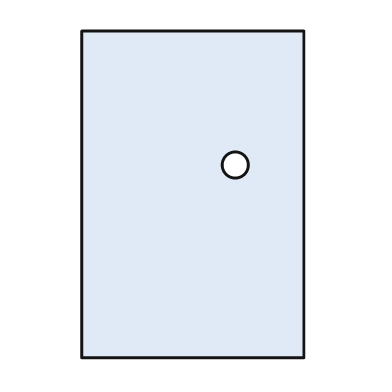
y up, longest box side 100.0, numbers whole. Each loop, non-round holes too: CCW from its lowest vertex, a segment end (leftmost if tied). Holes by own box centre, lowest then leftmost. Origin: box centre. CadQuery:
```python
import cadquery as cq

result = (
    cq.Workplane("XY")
    .moveTo(-34.0, -50.0)
    .lineTo(34.0, -50.0)
    .lineTo(34.0, 50.0)
    .lineTo(-34.0, 50.0)
    .close()
    .moveTo(13.0, 9.0)
    .circle(4.0)
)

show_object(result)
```